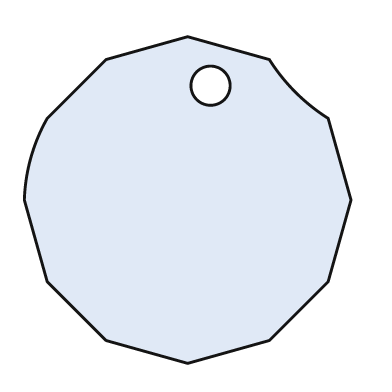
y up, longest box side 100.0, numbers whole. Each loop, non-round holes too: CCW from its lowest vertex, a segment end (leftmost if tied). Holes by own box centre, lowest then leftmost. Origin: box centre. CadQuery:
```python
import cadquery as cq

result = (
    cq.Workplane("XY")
    .moveTo(0.0, -50.0)
    .lineTo(25.0, -43.0)
    .lineTo(43.0, -25.0)
    .lineTo(50.0, 0.0)
    .lineTo(43.0, 25.0)
    .threePointArc((33.0, 33.0), (25.0, 43.0))
    .lineTo(0.0, 50.0)
    .lineTo(-25.0, 43.0)
    .lineTo(-43.0, 25.0)
    .threePointArc((-48.0, 13.0), (-50.0, 0.0))
    .lineTo(-43.0, -25.0)
    .lineTo(-25.0, -43.0)
    .close()
    .moveTo(7.0, 35.0)
    .circle(6.0)
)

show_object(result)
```